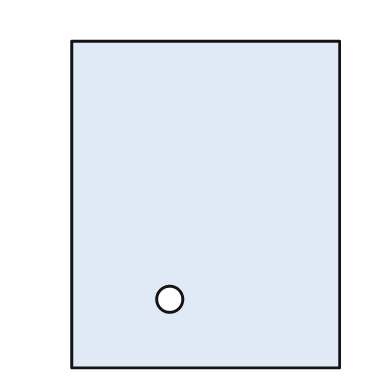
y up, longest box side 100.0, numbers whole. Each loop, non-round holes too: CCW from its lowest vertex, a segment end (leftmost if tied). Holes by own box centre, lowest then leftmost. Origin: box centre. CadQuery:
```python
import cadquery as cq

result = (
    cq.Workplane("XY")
    .moveTo(-41.0, -50.0)
    .lineTo(41.0, -50.0)
    .lineTo(41.0, 50.0)
    .lineTo(-41.0, 50.0)
    .close()
    .moveTo(-11.0, -29.0)
    .circle(4.0)
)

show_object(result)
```